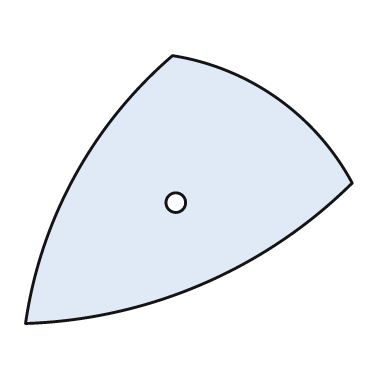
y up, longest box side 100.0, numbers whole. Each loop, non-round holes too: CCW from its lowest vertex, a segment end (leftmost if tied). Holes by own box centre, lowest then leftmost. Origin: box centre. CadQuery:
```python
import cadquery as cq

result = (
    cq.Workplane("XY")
    .moveTo(-50.0, -41.0)
    .threePointArc((4.0, -29.0), (50.0, 2.0))
    .threePointArc((27.0, 28.0), (-5.0, 41.0))
    .threePointArc((-35.0, 4.0), (-50.0, -41.0))
    .close()
    .moveTo(-4.0, -4.0)
    .circle(3.0)
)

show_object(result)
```